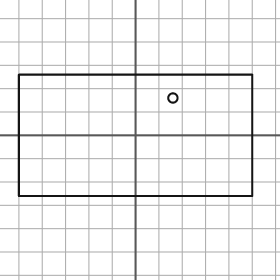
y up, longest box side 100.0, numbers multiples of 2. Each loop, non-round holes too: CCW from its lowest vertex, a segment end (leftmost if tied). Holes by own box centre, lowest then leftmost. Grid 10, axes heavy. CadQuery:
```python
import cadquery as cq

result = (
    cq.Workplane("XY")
    .moveTo(-50.0, -26.0)
    .lineTo(50.0, -26.0)
    .lineTo(50.0, 26.0)
    .lineTo(-50.0, 26.0)
    .close()
    .moveTo(16.0, 16.0)
    .circle(2.0)
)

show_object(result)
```